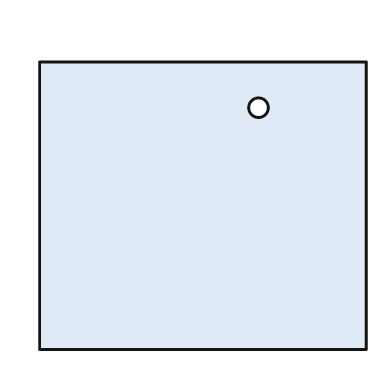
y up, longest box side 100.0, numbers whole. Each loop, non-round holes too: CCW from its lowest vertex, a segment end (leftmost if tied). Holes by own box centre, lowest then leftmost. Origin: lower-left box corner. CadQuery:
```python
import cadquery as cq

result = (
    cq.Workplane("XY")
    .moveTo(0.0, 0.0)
    .lineTo(100.0, 0.0)
    .lineTo(100.0, 88.0)
    .lineTo(0.0, 88.0)
    .close()
    .moveTo(67.0, 74.0)
    .circle(3.0)
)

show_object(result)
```